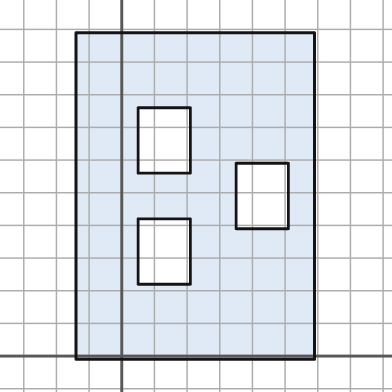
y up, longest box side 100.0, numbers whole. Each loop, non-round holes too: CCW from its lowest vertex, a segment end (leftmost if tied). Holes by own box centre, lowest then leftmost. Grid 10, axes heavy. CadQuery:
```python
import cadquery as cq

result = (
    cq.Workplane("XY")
    .moveTo(-14.0, -1.0)
    .lineTo(59.0, -1.0)
    .lineTo(59.0, 99.0)
    .lineTo(-14.0, 99.0)
    .close()
    .moveTo(5.0, 22.0)
    .lineTo(21.0, 22.0)
    .lineTo(21.0, 42.0)
    .lineTo(5.0, 42.0)
    .close()
    .moveTo(35.0, 39.0)
    .lineTo(51.0, 39.0)
    .lineTo(51.0, 59.0)
    .lineTo(35.0, 59.0)
    .close()
    .moveTo(5.0, 56.0)
    .lineTo(21.0, 56.0)
    .lineTo(21.0, 76.0)
    .lineTo(5.0, 76.0)
    .close()
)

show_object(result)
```